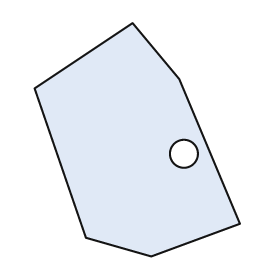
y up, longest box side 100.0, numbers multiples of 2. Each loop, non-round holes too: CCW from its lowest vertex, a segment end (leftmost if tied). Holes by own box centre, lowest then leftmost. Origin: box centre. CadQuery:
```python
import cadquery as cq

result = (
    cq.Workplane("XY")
    .moveTo(6.0, -50.0)
    .lineTo(44.0, -36.0)
    .lineTo(18.0, 26.0)
    .lineTo(-2.0, 50.0)
    .lineTo(-44.0, 22.0)
    .lineTo(-22.0, -42.0)
    .close()
    .moveTo(20.0, -6.0)
    .circle(6.0)
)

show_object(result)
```